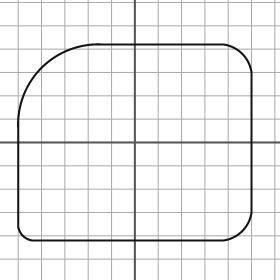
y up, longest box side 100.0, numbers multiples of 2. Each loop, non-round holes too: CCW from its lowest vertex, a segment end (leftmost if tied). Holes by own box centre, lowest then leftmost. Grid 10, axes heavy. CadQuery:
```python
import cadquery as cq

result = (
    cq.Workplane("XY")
    .moveTo(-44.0, -42.0)
    .lineTo(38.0, -42.0)
    .threePointArc((46.0, -38.0), (50.0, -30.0))
    .lineTo(50.0, 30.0)
    .threePointArc((46.0, 38.0), (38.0, 42.0))
    .lineTo(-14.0, 42.0)
    .threePointArc((-40.0, 32.0), (-50.0, 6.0))
    .lineTo(-50.0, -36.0)
    .threePointArc((-48.0, -40.0), (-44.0, -42.0))
    .close()
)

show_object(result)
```